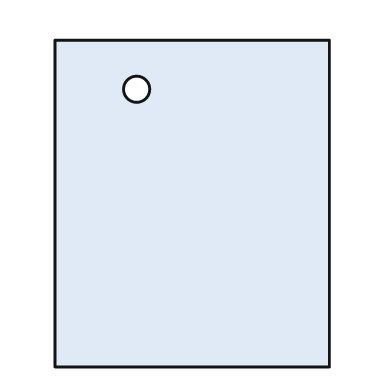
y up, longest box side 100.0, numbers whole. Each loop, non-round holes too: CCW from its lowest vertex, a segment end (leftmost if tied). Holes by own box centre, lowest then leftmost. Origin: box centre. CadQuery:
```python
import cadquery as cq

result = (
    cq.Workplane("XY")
    .moveTo(-42.0, -50.0)
    .lineTo(42.0, -50.0)
    .lineTo(42.0, 50.0)
    .lineTo(-42.0, 50.0)
    .close()
    .moveTo(-17.0, 35.0)
    .circle(4.0)
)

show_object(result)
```